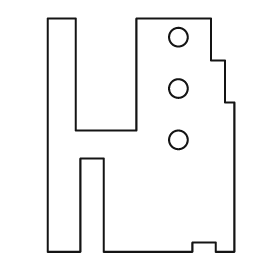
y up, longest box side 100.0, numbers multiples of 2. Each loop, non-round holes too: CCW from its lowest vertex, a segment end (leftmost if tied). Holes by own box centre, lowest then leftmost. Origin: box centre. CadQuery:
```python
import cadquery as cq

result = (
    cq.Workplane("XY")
    .moveTo(-40.0, -50.0)
    .lineTo(-26.0, -50.0)
    .lineTo(-26.0, -10.0)
    .lineTo(-16.0, -10.0)
    .lineTo(-16.0, -50.0)
    .lineTo(22.0, -50.0)
    .lineTo(22.0, -46.0)
    .lineTo(32.0, -46.0)
    .lineTo(32.0, -50.0)
    .lineTo(40.0, -50.0)
    .lineTo(40.0, 14.0)
    .lineTo(36.0, 14.0)
    .lineTo(36.0, 32.0)
    .lineTo(30.0, 32.0)
    .lineTo(30.0, 50.0)
    .lineTo(-2.0, 50.0)
    .lineTo(-2.0, 2.0)
    .lineTo(-28.0, 2.0)
    .lineTo(-28.0, 50.0)
    .lineTo(-40.0, 50.0)
    .close()
    .moveTo(16.0, -2.0)
    .circle(4.0)
    .moveTo(16.0, 20.0)
    .circle(4.0)
    .moveTo(16.0, 42.0)
    .circle(4.0)
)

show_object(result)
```